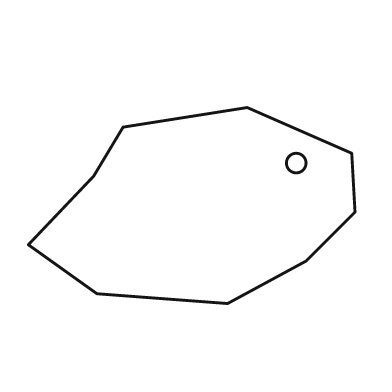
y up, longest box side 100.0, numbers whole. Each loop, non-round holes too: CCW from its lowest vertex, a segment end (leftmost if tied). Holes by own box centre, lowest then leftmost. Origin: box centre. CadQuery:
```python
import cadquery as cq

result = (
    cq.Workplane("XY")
    .moveTo(11.0, -30.0)
    .lineTo(35.0, -17.0)
    .lineTo(50.0, -2.0)
    .lineTo(49.0, 16.0)
    .lineTo(17.0, 30.0)
    .lineTo(-21.0, 24.0)
    .lineTo(-30.0, 9.0)
    .lineTo(-50.0, -12.0)
    .lineTo(-29.0, -27.0)
    .close()
    .moveTo(32.0, 13.0)
    .circle(3.0)
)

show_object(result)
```